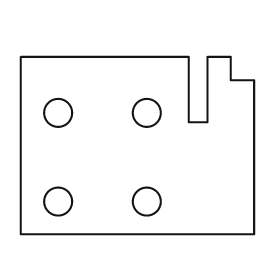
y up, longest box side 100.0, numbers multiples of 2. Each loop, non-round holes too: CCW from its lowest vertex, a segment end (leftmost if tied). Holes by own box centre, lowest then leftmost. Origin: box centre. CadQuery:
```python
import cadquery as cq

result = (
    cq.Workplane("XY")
    .moveTo(-50.0, -38.0)
    .lineTo(50.0, -38.0)
    .lineTo(50.0, 28.0)
    .lineTo(40.0, 28.0)
    .lineTo(40.0, 38.0)
    .lineTo(30.0, 38.0)
    .lineTo(30.0, 10.0)
    .lineTo(22.0, 10.0)
    .lineTo(22.0, 38.0)
    .lineTo(-50.0, 38.0)
    .close()
    .moveTo(-34.0, -24.0)
    .circle(6.0)
    .moveTo(4.0, -24.0)
    .circle(6.0)
    .moveTo(-34.0, 14.0)
    .circle(6.0)
    .moveTo(4.0, 14.0)
    .circle(6.0)
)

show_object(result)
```